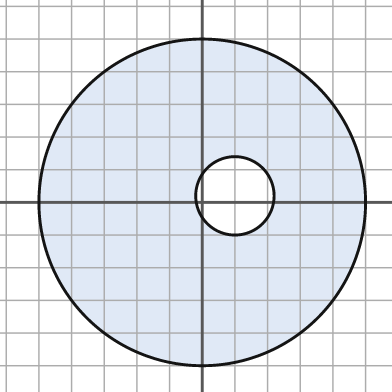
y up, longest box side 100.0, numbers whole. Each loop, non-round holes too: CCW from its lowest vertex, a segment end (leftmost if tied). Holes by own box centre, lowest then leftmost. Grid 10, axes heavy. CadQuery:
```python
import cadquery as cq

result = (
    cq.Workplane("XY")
    .moveTo(0.0, 0.0)
    .circle(50.0)
    .moveTo(10.0, 2.0)
    .circle(12.0)
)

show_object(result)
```